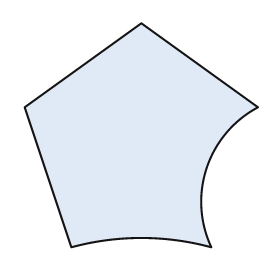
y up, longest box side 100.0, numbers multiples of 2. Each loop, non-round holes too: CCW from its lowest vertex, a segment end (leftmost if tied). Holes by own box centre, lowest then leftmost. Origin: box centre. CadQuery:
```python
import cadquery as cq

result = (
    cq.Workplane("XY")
    .moveTo(-30.0, -48.0)
    .threePointArc((0.0, -44.0), (30.0, -48.0))
    .threePointArc((28.0, -14.0), (50.0, 12.0))
    .lineTo(0.0, 48.0)
    .lineTo(-50.0, 12.0)
    .close()
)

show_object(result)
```